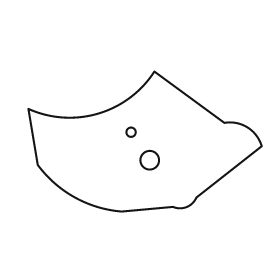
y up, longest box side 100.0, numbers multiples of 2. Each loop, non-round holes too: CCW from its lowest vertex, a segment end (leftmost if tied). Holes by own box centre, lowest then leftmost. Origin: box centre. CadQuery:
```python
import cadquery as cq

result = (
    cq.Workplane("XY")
    .moveTo(-10.0, -30.0)
    .lineTo(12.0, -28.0)
    .threePointArc((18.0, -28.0), (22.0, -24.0))
    .lineTo(50.0, -2.0)
    .threePointArc((44.0, 6.0), (34.0, 8.0))
    .lineTo(4.0, 30.0)
    .threePointArc((-20.0, 12.0), (-50.0, 14.0))
    .lineTo(-46.0, -10.0)
    .threePointArc((-30.0, -24.0), (-10.0, -30.0))
    .close()
    .moveTo(2.0, -8.0)
    .circle(4.0)
    .moveTo(-6.0, 4.0)
    .circle(2.0)
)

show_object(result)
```